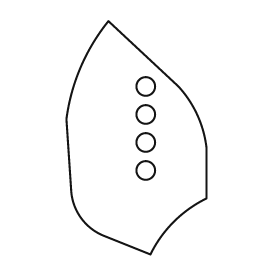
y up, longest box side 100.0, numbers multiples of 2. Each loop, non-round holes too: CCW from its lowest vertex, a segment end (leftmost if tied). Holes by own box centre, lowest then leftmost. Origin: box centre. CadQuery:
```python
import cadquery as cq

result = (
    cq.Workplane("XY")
    .moveTo(6.0, -50.0)
    .threePointArc((16.0, -36.0), (30.0, -26.0))
    .lineTo(30.0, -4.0)
    .threePointArc((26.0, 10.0), (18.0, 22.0))
    .lineTo(-12.0, 50.0)
    .threePointArc((-24.0, 30.0), (-30.0, 8.0))
    .lineTo(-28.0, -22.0)
    .threePointArc((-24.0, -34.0), (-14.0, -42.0))
    .close()
    .moveTo(4.0, -14.0)
    .circle(4.0)
    .moveTo(4.0, -2.0)
    .circle(4.0)
    .moveTo(4.0, 10.0)
    .circle(4.0)
    .moveTo(4.0, 22.0)
    .circle(4.0)
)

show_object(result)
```